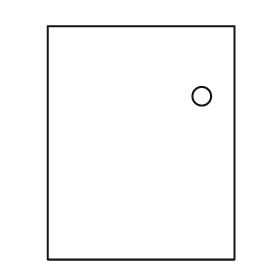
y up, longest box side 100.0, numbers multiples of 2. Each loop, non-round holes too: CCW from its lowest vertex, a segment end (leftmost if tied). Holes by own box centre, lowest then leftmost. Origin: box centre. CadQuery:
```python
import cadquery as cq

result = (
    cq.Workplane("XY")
    .moveTo(-40.0, -50.0)
    .lineTo(40.0, -50.0)
    .lineTo(40.0, 50.0)
    .lineTo(-40.0, 50.0)
    .close()
    .moveTo(26.0, 20.0)
    .circle(4.0)
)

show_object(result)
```